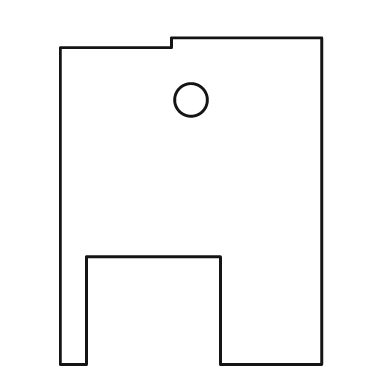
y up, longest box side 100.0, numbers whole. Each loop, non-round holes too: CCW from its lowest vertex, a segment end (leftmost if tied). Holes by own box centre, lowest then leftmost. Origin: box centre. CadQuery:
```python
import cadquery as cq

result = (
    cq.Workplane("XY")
    .moveTo(-40.0, -50.0)
    .lineTo(-32.0, -50.0)
    .lineTo(-32.0, -17.0)
    .lineTo(9.0, -17.0)
    .lineTo(9.0, -50.0)
    .lineTo(40.0, -50.0)
    .lineTo(40.0, 50.0)
    .lineTo(-6.0, 50.0)
    .lineTo(-6.0, 47.0)
    .lineTo(-40.0, 47.0)
    .close()
    .moveTo(0.0, 31.0)
    .circle(5.0)
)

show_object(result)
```